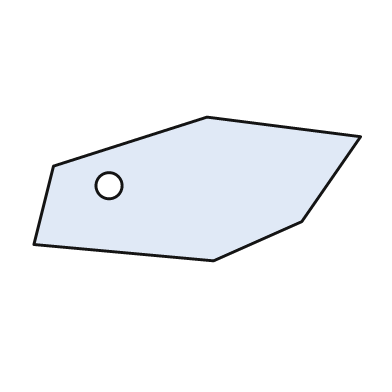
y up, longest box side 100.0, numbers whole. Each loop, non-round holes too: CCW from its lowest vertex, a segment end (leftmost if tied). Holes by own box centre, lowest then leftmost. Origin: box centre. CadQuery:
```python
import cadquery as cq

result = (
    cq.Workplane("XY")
    .moveTo(5.0, -22.0)
    .lineTo(32.0, -10.0)
    .lineTo(50.0, 16.0)
    .lineTo(3.0, 22.0)
    .lineTo(-44.0, 7.0)
    .lineTo(-50.0, -17.0)
    .close()
    .moveTo(-27.0, 1.0)
    .circle(4.0)
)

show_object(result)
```